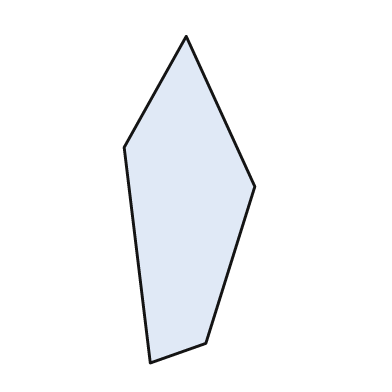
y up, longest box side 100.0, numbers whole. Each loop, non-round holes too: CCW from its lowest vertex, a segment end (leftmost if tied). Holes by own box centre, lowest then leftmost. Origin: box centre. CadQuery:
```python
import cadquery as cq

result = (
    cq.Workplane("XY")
    .moveTo(-12.0, -50.0)
    .lineTo(5.0, -44.0)
    .lineTo(20.0, 4.0)
    .lineTo(-1.0, 50.0)
    .lineTo(-20.0, 16.0)
    .close()
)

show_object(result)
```